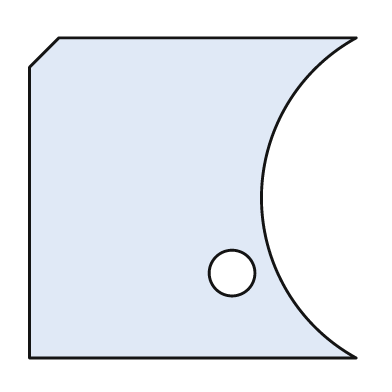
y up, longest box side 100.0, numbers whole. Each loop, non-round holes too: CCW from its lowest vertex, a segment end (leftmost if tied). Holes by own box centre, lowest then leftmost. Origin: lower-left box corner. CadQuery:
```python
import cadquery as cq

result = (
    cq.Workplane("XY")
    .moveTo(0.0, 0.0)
    .lineTo(100.0, 0.0)
    .threePointArc((71.0, 49.0), (100.0, 98.0))
    .lineTo(9.0, 98.0)
    .lineTo(0.0, 89.0)
    .close()
    .moveTo(62.0, 26.0)
    .circle(7.0)
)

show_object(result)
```